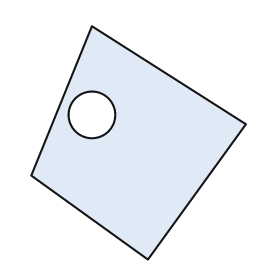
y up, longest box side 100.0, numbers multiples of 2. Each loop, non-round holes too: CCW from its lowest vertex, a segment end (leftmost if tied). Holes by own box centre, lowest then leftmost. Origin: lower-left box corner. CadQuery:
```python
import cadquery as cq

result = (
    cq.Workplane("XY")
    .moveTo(50.0, 0.0)
    .lineTo(92.0, 58.0)
    .lineTo(26.0, 100.0)
    .lineTo(0.0, 36.0)
    .close()
    .moveTo(26.0, 62.0)
    .circle(10.0)
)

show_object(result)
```